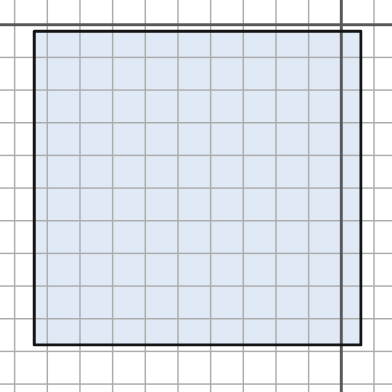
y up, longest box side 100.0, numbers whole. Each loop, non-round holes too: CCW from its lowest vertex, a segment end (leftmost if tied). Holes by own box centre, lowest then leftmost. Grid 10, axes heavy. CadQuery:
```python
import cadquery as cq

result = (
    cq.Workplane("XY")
    .moveTo(-94.0, -98.0)
    .lineTo(6.0, -98.0)
    .lineTo(6.0, -2.0)
    .lineTo(-94.0, -2.0)
    .close()
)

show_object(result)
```